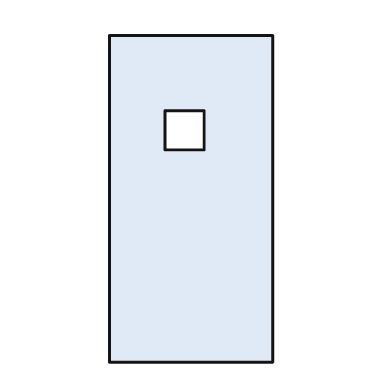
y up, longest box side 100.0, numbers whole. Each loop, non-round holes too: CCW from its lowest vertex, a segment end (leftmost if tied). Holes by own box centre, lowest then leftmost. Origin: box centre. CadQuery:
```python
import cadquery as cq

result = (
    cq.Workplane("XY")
    .moveTo(-25.0, -50.0)
    .lineTo(25.0, -50.0)
    .lineTo(25.0, 50.0)
    .lineTo(-25.0, 50.0)
    .close()
    .moveTo(-8.0, 15.0)
    .lineTo(4.0, 15.0)
    .lineTo(4.0, 27.0)
    .lineTo(-8.0, 27.0)
    .close()
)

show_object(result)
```